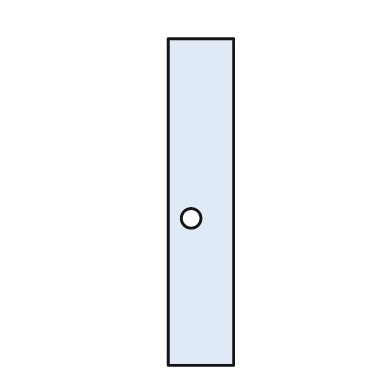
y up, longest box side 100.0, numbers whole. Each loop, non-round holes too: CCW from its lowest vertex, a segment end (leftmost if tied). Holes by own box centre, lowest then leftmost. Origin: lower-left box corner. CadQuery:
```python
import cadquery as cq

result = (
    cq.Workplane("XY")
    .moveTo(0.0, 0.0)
    .lineTo(20.0, 0.0)
    .lineTo(20.0, 100.0)
    .lineTo(0.0, 100.0)
    .close()
    .moveTo(7.0, 45.0)
    .circle(3.0)
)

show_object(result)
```